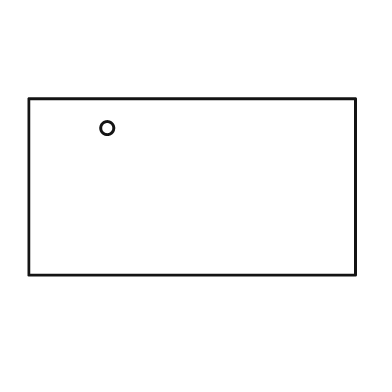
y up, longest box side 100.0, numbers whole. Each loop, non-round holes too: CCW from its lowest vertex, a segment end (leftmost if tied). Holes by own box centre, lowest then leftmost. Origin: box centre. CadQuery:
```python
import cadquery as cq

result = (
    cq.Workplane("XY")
    .moveTo(-50.0, -27.0)
    .lineTo(50.0, -27.0)
    .lineTo(50.0, 27.0)
    .lineTo(-50.0, 27.0)
    .close()
    .moveTo(-26.0, 18.0)
    .circle(2.0)
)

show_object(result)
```